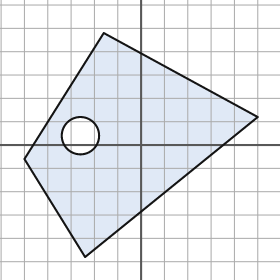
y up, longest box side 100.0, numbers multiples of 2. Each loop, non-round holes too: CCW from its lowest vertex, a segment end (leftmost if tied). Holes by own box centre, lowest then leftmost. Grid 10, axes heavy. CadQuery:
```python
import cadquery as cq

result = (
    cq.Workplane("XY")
    .moveTo(-24.0, -48.0)
    .lineTo(50.0, 12.0)
    .lineTo(-16.0, 48.0)
    .lineTo(-50.0, -6.0)
    .close()
    .moveTo(-26.0, 4.0)
    .circle(8.0)
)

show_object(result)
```